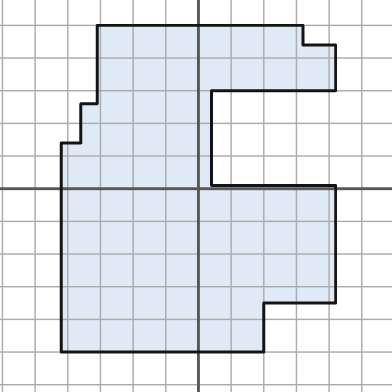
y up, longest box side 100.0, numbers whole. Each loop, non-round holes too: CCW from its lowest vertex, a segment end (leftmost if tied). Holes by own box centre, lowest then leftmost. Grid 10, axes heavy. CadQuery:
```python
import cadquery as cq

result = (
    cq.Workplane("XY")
    .moveTo(-42.0, -50.0)
    .lineTo(20.0, -50.0)
    .lineTo(20.0, -35.0)
    .lineTo(42.0, -35.0)
    .lineTo(42.0, 1.0)
    .lineTo(4.0, 1.0)
    .lineTo(4.0, 30.0)
    .lineTo(42.0, 30.0)
    .lineTo(42.0, 44.0)
    .lineTo(32.0, 44.0)
    .lineTo(32.0, 50.0)
    .lineTo(-31.0, 50.0)
    .lineTo(-31.0, 26.0)
    .lineTo(-36.0, 26.0)
    .lineTo(-36.0, 14.0)
    .lineTo(-42.0, 14.0)
    .close()
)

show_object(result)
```